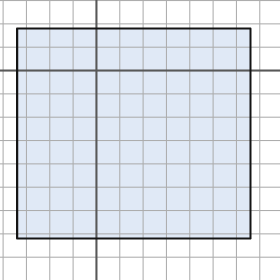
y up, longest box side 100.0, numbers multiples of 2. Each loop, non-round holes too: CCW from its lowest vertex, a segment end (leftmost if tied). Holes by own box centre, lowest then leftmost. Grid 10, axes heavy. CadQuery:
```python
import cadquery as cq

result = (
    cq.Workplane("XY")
    .moveTo(-34.0, -72.0)
    .lineTo(66.0, -72.0)
    .lineTo(66.0, 18.0)
    .lineTo(-34.0, 18.0)
    .close()
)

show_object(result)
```